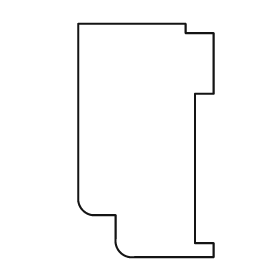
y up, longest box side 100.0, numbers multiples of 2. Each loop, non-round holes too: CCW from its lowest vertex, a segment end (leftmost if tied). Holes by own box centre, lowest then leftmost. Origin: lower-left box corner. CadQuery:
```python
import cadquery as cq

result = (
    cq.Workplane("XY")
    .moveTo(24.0, 0.0)
    .lineTo(58.0, 0.0)
    .lineTo(58.0, 6.0)
    .lineTo(50.0, 6.0)
    .lineTo(50.0, 70.0)
    .lineTo(58.0, 70.0)
    .lineTo(58.0, 96.0)
    .lineTo(46.0, 96.0)
    .lineTo(46.0, 100.0)
    .lineTo(0.0, 100.0)
    .lineTo(0.0, 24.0)
    .threePointArc((2.0, 20.0), (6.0, 18.0))
    .lineTo(16.0, 18.0)
    .lineTo(16.0, 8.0)
    .threePointArc((18.0, 2.0), (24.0, 0.0))
    .close()
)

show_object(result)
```